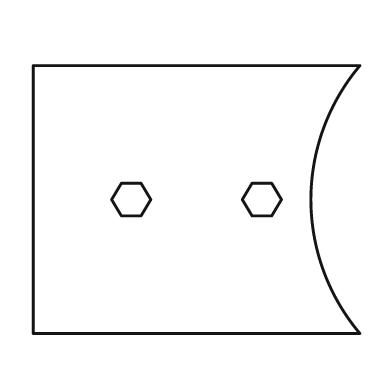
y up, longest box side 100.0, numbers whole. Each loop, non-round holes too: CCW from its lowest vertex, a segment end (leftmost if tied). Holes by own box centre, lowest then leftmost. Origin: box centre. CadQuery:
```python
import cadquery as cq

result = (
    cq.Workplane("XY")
    .moveTo(-50.0, -41.0)
    .lineTo(50.0, -41.0)
    .threePointArc((35.0, 0.0), (50.0, 41.0))
    .lineTo(-50.0, 41.0)
    .close()
    .moveTo(-23.0, -5.0)
    .lineTo(-17.0, -5.0)
    .lineTo(-14.0, 0.0)
    .lineTo(-17.0, 5.0)
    .lineTo(-23.0, 5.0)
    .lineTo(-26.0, 0.0)
    .close()
    .moveTo(17.0, -5.0)
    .lineTo(23.0, -5.0)
    .lineTo(26.0, 0.0)
    .lineTo(23.0, 5.0)
    .lineTo(17.0, 5.0)
    .lineTo(14.0, 0.0)
    .close()
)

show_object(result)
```